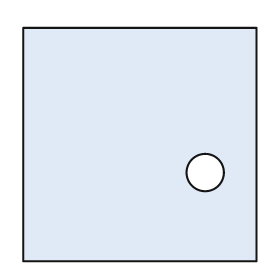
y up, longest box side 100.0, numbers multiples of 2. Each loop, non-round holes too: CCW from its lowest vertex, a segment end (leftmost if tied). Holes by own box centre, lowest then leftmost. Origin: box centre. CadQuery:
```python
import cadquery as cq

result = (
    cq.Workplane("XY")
    .moveTo(-50.0, -50.0)
    .lineTo(50.0, -50.0)
    .lineTo(50.0, 50.0)
    .lineTo(-50.0, 50.0)
    .close()
    .moveTo(28.0, -12.0)
    .circle(8.0)
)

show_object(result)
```